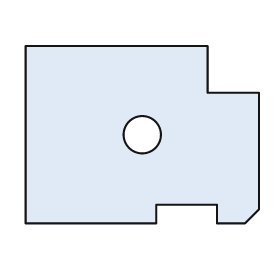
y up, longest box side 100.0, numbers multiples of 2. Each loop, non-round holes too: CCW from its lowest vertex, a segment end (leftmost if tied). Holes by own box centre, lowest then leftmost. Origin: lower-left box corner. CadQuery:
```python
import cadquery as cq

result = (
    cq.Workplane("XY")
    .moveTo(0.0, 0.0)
    .lineTo(56.0, 0.0)
    .lineTo(56.0, 8.0)
    .lineTo(82.0, 8.0)
    .lineTo(82.0, 0.0)
    .lineTo(94.0, 0.0)
    .lineTo(100.0, 6.0)
    .lineTo(100.0, 56.0)
    .lineTo(78.0, 56.0)
    .lineTo(78.0, 76.0)
    .lineTo(0.0, 76.0)
    .close()
    .moveTo(50.0, 38.0)
    .circle(8.0)
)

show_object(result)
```